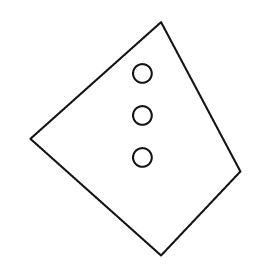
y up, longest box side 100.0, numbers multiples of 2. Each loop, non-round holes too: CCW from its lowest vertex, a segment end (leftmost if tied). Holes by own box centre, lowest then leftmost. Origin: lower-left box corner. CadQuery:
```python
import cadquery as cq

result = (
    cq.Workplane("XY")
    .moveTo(56.0, 0.0)
    .lineTo(90.0, 36.0)
    .lineTo(56.0, 100.0)
    .lineTo(0.0, 50.0)
    .close()
    .moveTo(48.0, 42.0)
    .circle(4.0)
    .moveTo(48.0, 60.0)
    .circle(4.0)
    .moveTo(48.0, 78.0)
    .circle(4.0)
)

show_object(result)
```